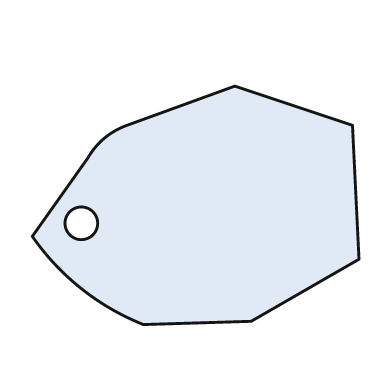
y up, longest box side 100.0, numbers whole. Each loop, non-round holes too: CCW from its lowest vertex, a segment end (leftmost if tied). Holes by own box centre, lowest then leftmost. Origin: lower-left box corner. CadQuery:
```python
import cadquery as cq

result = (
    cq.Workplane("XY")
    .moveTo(34.0, 0.0)
    .lineTo(67.0, 1.0)
    .lineTo(100.0, 20.0)
    .lineTo(98.0, 61.0)
    .lineTo(62.0, 73.0)
    .lineTo(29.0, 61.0)
    .threePointArc((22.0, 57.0), (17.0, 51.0))
    .lineTo(0.0, 27.0)
    .threePointArc((15.0, 11.0), (34.0, 0.0))
    .close()
    .moveTo(15.0, 31.0)
    .circle(5.0)
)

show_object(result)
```